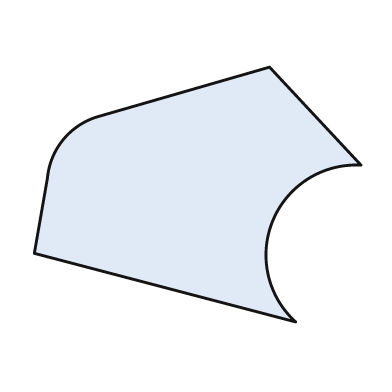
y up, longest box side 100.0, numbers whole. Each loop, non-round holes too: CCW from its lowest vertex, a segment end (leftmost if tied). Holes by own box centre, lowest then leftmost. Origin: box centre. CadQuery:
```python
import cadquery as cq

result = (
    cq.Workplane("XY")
    .moveTo(30.0, -39.0)
    .threePointArc((23.0, -8.0), (50.0, 9.0))
    .lineTo(22.0, 39.0)
    .lineTo(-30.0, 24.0)
    .threePointArc((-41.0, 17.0), (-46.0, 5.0))
    .lineTo(-50.0, -18.0)
    .close()
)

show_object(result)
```